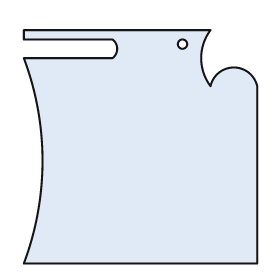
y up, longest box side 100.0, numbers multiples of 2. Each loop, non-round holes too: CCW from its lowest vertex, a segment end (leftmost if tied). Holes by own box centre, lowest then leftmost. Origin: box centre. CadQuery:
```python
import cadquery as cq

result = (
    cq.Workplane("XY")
    .moveTo(-50.0, -50.0)
    .lineTo(50.0, -50.0)
    .lineTo(50.0, 26.0)
    .threePointArc((40.0, 34.0), (30.0, 26.0))
    .threePointArc((26.0, 38.0), (30.0, 50.0))
    .lineTo(-50.0, 50.0)
    .lineTo(-50.0, 46.0)
    .lineTo(-12.0, 46.0)
    .threePointArc((-10.0, 42.0), (-12.0, 38.0))
    .lineTo(-50.0, 38.0)
    .threePointArc((-42.0, -6.0), (-50.0, -50.0))
    .close()
    .moveTo(18.0, 44.0)
    .circle(2.0)
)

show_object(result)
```